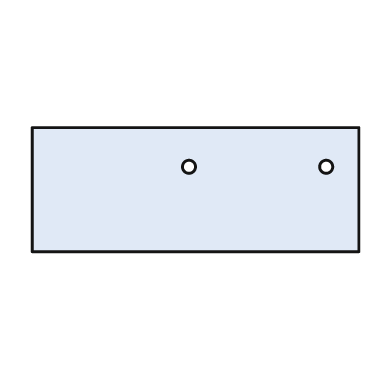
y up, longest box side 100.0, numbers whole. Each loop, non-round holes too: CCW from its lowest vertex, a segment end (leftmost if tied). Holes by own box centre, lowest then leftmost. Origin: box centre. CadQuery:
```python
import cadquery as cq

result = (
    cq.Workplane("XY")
    .moveTo(-50.0, -19.0)
    .lineTo(50.0, -19.0)
    .lineTo(50.0, 19.0)
    .lineTo(-50.0, 19.0)
    .close()
    .moveTo(-2.0, 7.0)
    .circle(2.0)
    .moveTo(40.0, 7.0)
    .circle(2.0)
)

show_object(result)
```